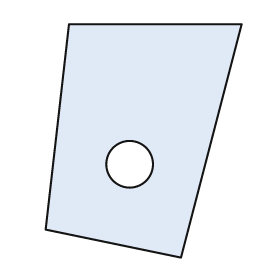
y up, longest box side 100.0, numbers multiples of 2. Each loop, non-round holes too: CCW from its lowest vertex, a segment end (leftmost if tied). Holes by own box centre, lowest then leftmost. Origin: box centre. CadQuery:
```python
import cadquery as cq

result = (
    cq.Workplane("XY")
    .moveTo(16.0, -50.0)
    .lineTo(42.0, 50.0)
    .lineTo(-32.0, 50.0)
    .lineTo(-42.0, -38.0)
    .close()
    .moveTo(-6.0, -10.0)
    .circle(10.0)
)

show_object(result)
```